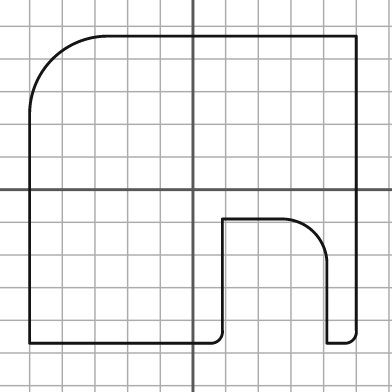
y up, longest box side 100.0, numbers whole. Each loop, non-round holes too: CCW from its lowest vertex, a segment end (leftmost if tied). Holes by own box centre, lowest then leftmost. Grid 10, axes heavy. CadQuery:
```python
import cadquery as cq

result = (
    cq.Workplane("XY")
    .moveTo(-50.0, -47.0)
    .lineTo(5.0, -47.0)
    .threePointArc((8.0, -46.0), (9.0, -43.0))
    .lineTo(9.0, -9.0)
    .lineTo(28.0, -9.0)
    .threePointArc((37.0, -13.0), (41.0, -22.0))
    .lineTo(41.0, -47.0)
    .lineTo(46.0, -47.0)
    .threePointArc((49.0, -46.0), (50.0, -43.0))
    .lineTo(50.0, 47.0)
    .lineTo(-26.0, 47.0)
    .threePointArc((-43.0, 40.0), (-50.0, 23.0))
    .close()
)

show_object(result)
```